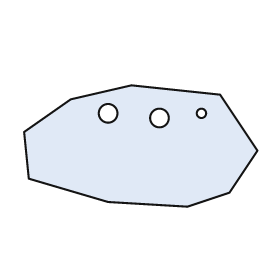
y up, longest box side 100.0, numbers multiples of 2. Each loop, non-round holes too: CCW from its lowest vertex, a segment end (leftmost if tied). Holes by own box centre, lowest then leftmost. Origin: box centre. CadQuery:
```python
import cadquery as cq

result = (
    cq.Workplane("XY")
    .moveTo(20.0, -26.0)
    .lineTo(38.0, -20.0)
    .lineTo(50.0, -2.0)
    .lineTo(34.0, 22.0)
    .lineTo(-4.0, 26.0)
    .lineTo(-30.0, 20.0)
    .lineTo(-50.0, 6.0)
    .lineTo(-48.0, -14.0)
    .lineTo(-14.0, -24.0)
    .close()
    .moveTo(8.0, 12.0)
    .circle(4.0)
    .moveTo(-14.0, 14.0)
    .circle(4.0)
    .moveTo(26.0, 14.0)
    .circle(2.0)
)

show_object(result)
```